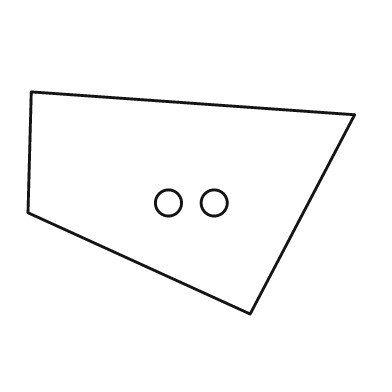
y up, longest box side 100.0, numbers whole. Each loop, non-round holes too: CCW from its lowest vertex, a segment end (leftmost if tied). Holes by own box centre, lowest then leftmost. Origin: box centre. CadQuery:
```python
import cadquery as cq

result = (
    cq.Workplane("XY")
    .moveTo(18.0, -34.0)
    .lineTo(50.0, 27.0)
    .lineTo(-49.0, 34.0)
    .lineTo(-50.0, -3.0)
    .close()
    .moveTo(-7.0, 0.0)
    .circle(4.0)
    .moveTo(7.0, 0.0)
    .circle(4.0)
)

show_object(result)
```